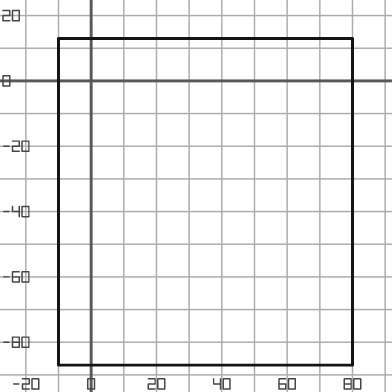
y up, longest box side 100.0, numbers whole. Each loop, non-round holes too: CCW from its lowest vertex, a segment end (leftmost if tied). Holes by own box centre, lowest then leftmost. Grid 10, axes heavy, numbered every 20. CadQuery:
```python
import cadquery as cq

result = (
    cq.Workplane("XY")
    .moveTo(-10.0, -87.0)
    .lineTo(80.0, -87.0)
    .lineTo(80.0, 13.0)
    .lineTo(-10.0, 13.0)
    .close()
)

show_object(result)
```